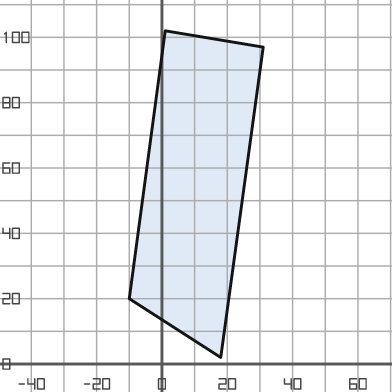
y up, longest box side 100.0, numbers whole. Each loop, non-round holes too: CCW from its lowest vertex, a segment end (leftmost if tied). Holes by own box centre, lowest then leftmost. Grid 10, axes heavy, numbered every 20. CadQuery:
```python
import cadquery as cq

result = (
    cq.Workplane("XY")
    .moveTo(18.0, 2.0)
    .lineTo(31.0, 97.0)
    .lineTo(1.0, 102.0)
    .lineTo(-10.0, 20.0)
    .close()
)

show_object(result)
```